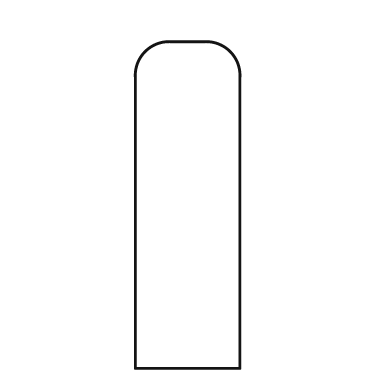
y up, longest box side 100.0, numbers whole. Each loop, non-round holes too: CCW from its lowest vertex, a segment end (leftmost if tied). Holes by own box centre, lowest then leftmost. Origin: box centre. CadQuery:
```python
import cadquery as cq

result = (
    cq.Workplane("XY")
    .moveTo(-16.0, -50.0)
    .lineTo(16.0, -50.0)
    .lineTo(16.0, 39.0)
    .threePointArc((13.0, 47.0), (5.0, 50.0))
    .lineTo(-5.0, 50.0)
    .threePointArc((-13.0, 47.0), (-16.0, 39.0))
    .close()
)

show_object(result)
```